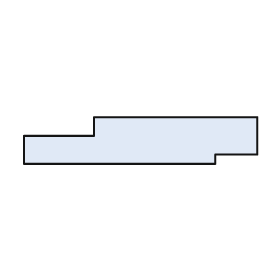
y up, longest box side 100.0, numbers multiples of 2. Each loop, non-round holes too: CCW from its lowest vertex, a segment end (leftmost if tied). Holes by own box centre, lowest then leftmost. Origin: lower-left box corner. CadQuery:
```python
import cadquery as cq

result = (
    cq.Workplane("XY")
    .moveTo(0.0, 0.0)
    .lineTo(82.0, 0.0)
    .lineTo(82.0, 4.0)
    .lineTo(100.0, 4.0)
    .lineTo(100.0, 20.0)
    .lineTo(30.0, 20.0)
    .lineTo(30.0, 12.0)
    .lineTo(0.0, 12.0)
    .close()
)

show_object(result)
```